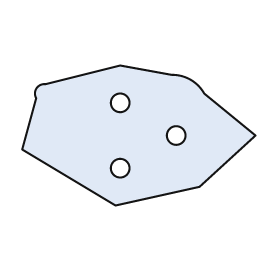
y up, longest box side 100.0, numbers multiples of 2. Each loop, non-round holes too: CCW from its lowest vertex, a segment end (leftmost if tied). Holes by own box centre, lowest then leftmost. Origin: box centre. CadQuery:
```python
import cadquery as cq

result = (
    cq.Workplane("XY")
    .moveTo(-10.0, -30.0)
    .lineTo(26.0, -22.0)
    .lineTo(50.0, 0.0)
    .lineTo(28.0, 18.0)
    .threePointArc((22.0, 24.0), (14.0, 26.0))
    .lineTo(-8.0, 30.0)
    .lineTo(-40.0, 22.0)
    .threePointArc((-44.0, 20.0), (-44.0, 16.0))
    .lineTo(-50.0, -6.0)
    .close()
    .moveTo(-8.0, -14.0)
    .circle(4.0)
    .moveTo(16.0, 0.0)
    .circle(4.0)
    .moveTo(-8.0, 14.0)
    .circle(4.0)
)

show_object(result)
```